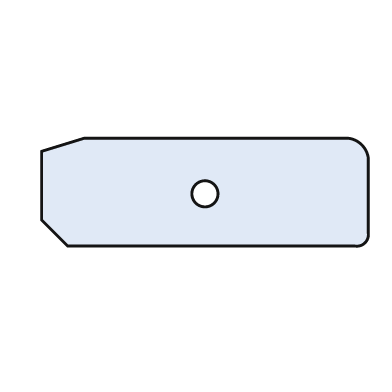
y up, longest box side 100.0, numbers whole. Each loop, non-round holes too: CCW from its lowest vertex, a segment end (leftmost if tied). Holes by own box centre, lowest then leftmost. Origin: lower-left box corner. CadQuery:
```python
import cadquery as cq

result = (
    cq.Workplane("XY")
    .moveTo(8.0, 0.0)
    .lineTo(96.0, 0.0)
    .threePointArc((99.0, 1.0), (100.0, 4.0))
    .lineTo(100.0, 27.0)
    .threePointArc((98.0, 31.0), (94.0, 33.0))
    .lineTo(13.0, 33.0)
    .lineTo(0.0, 29.0)
    .lineTo(0.0, 8.0)
    .close()
    .moveTo(50.0, 16.0)
    .circle(4.0)
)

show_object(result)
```